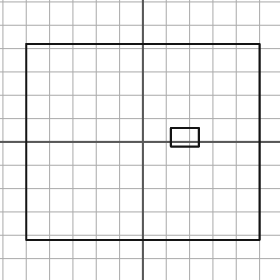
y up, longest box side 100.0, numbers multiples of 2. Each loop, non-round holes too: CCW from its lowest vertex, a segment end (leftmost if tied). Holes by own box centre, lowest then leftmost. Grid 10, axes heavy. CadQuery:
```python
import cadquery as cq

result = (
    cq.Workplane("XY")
    .moveTo(-50.0, -42.0)
    .lineTo(50.0, -42.0)
    .lineTo(50.0, 42.0)
    .lineTo(-50.0, 42.0)
    .close()
    .moveTo(12.0, -2.0)
    .lineTo(24.0, -2.0)
    .lineTo(24.0, 6.0)
    .lineTo(12.0, 6.0)
    .close()
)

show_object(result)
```